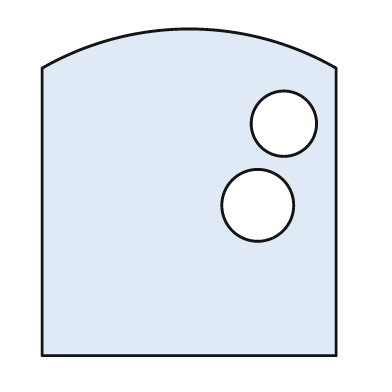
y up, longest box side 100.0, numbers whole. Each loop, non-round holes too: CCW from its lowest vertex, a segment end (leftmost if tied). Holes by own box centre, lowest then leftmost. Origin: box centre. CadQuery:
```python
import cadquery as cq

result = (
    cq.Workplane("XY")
    .moveTo(-45.0, -50.0)
    .lineTo(45.0, -50.0)
    .lineTo(45.0, 38.0)
    .threePointArc((0.0, 50.0), (-45.0, 38.0))
    .close()
    .moveTo(21.0, -4.0)
    .circle(11.0)
    .moveTo(29.0, 21.0)
    .circle(10.0)
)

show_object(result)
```